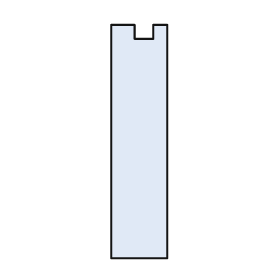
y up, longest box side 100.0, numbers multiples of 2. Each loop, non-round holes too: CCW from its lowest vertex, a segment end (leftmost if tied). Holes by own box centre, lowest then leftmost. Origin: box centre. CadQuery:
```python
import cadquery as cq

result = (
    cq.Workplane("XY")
    .moveTo(-12.0, -50.0)
    .lineTo(12.0, -50.0)
    .lineTo(12.0, 50.0)
    .lineTo(6.0, 50.0)
    .lineTo(6.0, 44.0)
    .lineTo(-2.0, 44.0)
    .lineTo(-2.0, 50.0)
    .lineTo(-12.0, 50.0)
    .close()
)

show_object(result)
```